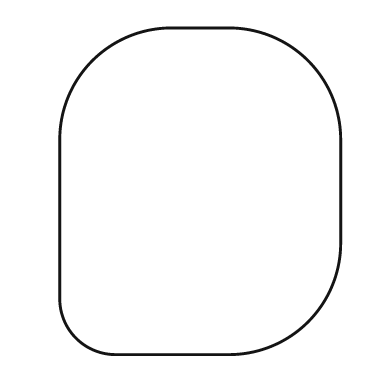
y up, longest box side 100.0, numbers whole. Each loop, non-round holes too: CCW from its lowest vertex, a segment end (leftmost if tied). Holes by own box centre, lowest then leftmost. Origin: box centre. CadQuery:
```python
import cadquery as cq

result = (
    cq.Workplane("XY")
    .moveTo(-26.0, -50.0)
    .lineTo(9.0, -50.0)
    .threePointArc((33.0, -40.0), (43.0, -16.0))
    .lineTo(43.0, 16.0)
    .threePointArc((33.0, 40.0), (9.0, 50.0))
    .lineTo(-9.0, 50.0)
    .threePointArc((-33.0, 40.0), (-43.0, 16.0))
    .lineTo(-43.0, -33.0)
    .threePointArc((-38.0, -45.0), (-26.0, -50.0))
    .close()
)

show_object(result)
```